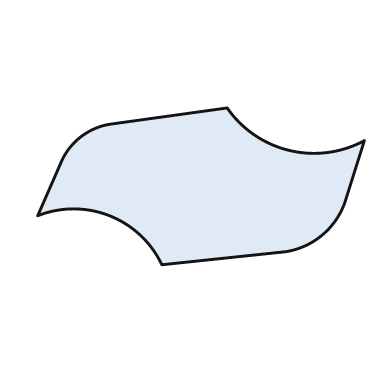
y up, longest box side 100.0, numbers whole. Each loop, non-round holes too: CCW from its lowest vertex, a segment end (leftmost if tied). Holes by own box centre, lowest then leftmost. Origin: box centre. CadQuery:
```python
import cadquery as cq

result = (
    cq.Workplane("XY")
    .moveTo(-12.0, -24.0)
    .lineTo(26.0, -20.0)
    .threePointArc((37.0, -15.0), (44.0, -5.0))
    .lineTo(50.0, 14.0)
    .threePointArc((27.0, 11.0), (8.0, 24.0))
    .lineTo(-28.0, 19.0)
    .threePointArc((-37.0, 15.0), (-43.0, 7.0))
    .lineTo(-50.0, -9.0)
    .threePointArc((-28.0, -9.0), (-12.0, -24.0))
    .close()
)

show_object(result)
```